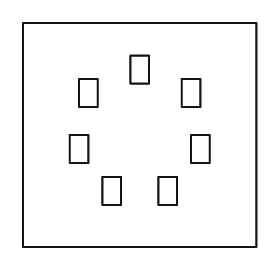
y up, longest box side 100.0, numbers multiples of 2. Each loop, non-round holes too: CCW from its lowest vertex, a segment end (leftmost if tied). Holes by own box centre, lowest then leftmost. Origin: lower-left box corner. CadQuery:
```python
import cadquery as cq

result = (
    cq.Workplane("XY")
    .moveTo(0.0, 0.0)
    .lineTo(100.0, 0.0)
    .lineTo(100.0, 96.0)
    .lineTo(0.0, 96.0)
    .close()
    .moveTo(34.0, 18.0)
    .lineTo(42.0, 18.0)
    .lineTo(42.0, 30.0)
    .lineTo(34.0, 30.0)
    .close()
    .moveTo(58.0, 18.0)
    .lineTo(66.0, 18.0)
    .lineTo(66.0, 30.0)
    .lineTo(58.0, 30.0)
    .close()
    .moveTo(20.0, 36.0)
    .lineTo(28.0, 36.0)
    .lineTo(28.0, 48.0)
    .lineTo(20.0, 48.0)
    .close()
    .moveTo(72.0, 36.0)
    .lineTo(80.0, 36.0)
    .lineTo(80.0, 48.0)
    .lineTo(72.0, 48.0)
    .close()
    .moveTo(24.0, 60.0)
    .lineTo(32.0, 60.0)
    .lineTo(32.0, 72.0)
    .lineTo(24.0, 72.0)
    .close()
    .moveTo(68.0, 60.0)
    .lineTo(76.0, 60.0)
    .lineTo(76.0, 72.0)
    .lineTo(68.0, 72.0)
    .close()
    .moveTo(46.0, 70.0)
    .lineTo(54.0, 70.0)
    .lineTo(54.0, 82.0)
    .lineTo(46.0, 82.0)
    .close()
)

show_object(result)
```